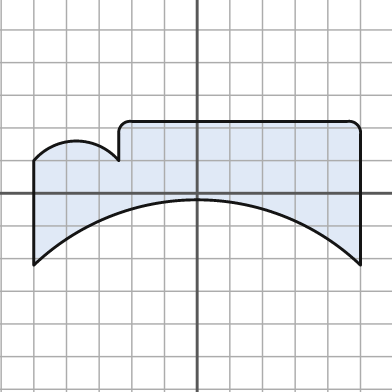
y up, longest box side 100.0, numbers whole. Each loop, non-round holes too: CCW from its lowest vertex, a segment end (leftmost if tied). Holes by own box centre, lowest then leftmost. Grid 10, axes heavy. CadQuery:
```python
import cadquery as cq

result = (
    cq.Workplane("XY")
    .moveTo(-50.0, -22.0)
    .threePointArc((0.0, -2.0), (50.0, -22.0))
    .lineTo(50.0, 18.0)
    .threePointArc((49.0, 21.0), (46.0, 22.0))
    .lineTo(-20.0, 22.0)
    .threePointArc((-23.0, 21.0), (-24.0, 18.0))
    .lineTo(-24.0, 10.0)
    .threePointArc((-37.0, 16.0), (-50.0, 10.0))
    .close()
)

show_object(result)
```